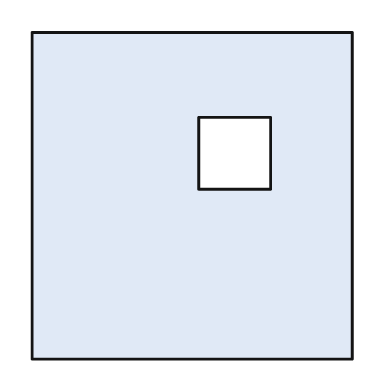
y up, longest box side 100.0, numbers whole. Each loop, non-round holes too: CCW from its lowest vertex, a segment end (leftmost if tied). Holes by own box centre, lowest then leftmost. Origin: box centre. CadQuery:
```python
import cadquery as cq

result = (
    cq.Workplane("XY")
    .moveTo(-49.0, -50.0)
    .lineTo(49.0, -50.0)
    .lineTo(49.0, 50.0)
    .lineTo(-49.0, 50.0)
    .close()
    .moveTo(2.0, 2.0)
    .lineTo(24.0, 2.0)
    .lineTo(24.0, 24.0)
    .lineTo(2.0, 24.0)
    .close()
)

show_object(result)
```